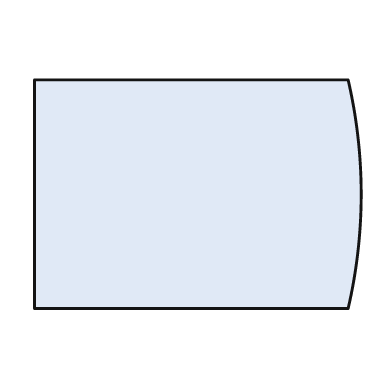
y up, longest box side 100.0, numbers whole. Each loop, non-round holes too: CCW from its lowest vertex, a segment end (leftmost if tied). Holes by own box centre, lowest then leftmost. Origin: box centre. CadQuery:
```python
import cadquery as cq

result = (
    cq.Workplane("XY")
    .moveTo(-50.0, -35.0)
    .lineTo(46.0, -35.0)
    .threePointArc((50.0, 0.0), (46.0, 35.0))
    .lineTo(-50.0, 35.0)
    .close()
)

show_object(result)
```